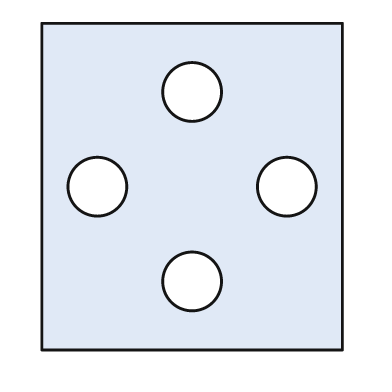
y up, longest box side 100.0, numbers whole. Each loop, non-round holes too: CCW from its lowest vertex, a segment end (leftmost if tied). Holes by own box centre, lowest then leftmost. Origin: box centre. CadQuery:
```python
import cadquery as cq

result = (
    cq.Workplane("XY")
    .moveTo(-46.0, -50.0)
    .lineTo(46.0, -50.0)
    .lineTo(46.0, 50.0)
    .lineTo(-46.0, 50.0)
    .close()
    .moveTo(0.0, -29.0)
    .circle(9.0)
    .moveTo(-29.0, 0.0)
    .circle(9.0)
    .moveTo(29.0, 0.0)
    .circle(9.0)
    .moveTo(0.0, 29.0)
    .circle(9.0)
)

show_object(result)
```